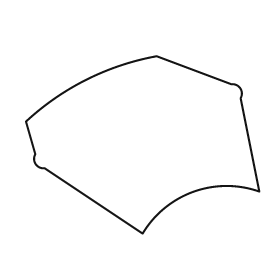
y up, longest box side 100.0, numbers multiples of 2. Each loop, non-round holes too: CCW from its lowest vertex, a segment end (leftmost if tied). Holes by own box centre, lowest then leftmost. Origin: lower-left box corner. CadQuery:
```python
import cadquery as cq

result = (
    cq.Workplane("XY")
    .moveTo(50.0, 0.0)
    .threePointArc((72.0, 18.0), (100.0, 18.0))
    .lineTo(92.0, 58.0)
    .threePointArc((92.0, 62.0), (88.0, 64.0))
    .lineTo(56.0, 76.0)
    .threePointArc((26.0, 66.0), (0.0, 48.0))
    .lineTo(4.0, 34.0)
    .threePointArc((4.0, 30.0), (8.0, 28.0))
    .close()
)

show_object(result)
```